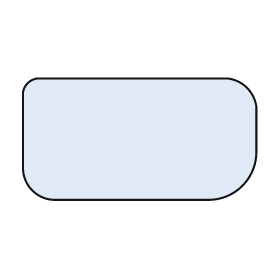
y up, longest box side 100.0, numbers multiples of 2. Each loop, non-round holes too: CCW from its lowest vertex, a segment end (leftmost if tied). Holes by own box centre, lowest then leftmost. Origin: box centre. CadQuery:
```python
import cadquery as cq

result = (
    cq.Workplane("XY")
    .moveTo(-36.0, -26.0)
    .lineTo(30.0, -26.0)
    .threePointArc((44.0, -20.0), (50.0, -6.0))
    .lineTo(50.0, 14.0)
    .threePointArc((46.0, 22.0), (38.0, 26.0))
    .lineTo(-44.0, 26.0)
    .threePointArc((-48.0, 24.0), (-50.0, 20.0))
    .lineTo(-50.0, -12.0)
    .threePointArc((-46.0, -22.0), (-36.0, -26.0))
    .close()
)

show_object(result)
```